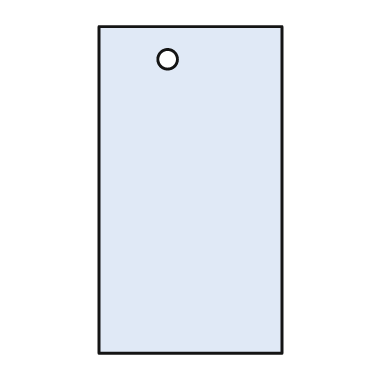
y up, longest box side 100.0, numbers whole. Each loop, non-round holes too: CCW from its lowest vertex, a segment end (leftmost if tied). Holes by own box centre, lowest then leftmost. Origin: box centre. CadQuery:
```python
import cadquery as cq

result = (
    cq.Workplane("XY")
    .moveTo(-28.0, -50.0)
    .lineTo(28.0, -50.0)
    .lineTo(28.0, 50.0)
    .lineTo(-28.0, 50.0)
    .close()
    .moveTo(-7.0, 40.0)
    .circle(3.0)
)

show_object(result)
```